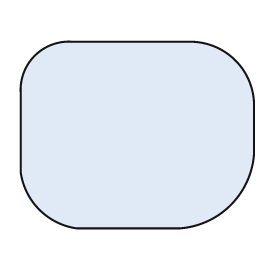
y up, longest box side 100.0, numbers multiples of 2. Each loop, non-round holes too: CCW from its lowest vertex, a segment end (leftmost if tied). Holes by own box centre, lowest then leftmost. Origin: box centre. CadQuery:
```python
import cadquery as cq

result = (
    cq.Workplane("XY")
    .moveTo(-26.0, -40.0)
    .lineTo(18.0, -40.0)
    .threePointArc((40.0, -30.0), (50.0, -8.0))
    .lineTo(50.0, 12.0)
    .threePointArc((42.0, 32.0), (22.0, 40.0))
    .lineTo(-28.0, 40.0)
    .threePointArc((-44.0, 34.0), (-50.0, 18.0))
    .lineTo(-50.0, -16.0)
    .threePointArc((-42.0, -32.0), (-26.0, -40.0))
    .close()
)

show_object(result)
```